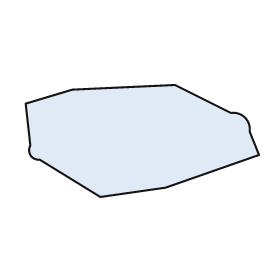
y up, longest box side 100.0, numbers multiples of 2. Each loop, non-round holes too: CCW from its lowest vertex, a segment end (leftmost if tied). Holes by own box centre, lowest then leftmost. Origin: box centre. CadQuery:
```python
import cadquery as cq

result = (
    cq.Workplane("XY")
    .moveTo(-18.0, -24.0)
    .lineTo(10.0, -20.0)
    .lineTo(50.0, -6.0)
    .lineTo(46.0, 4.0)
    .threePointArc((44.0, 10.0), (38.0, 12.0))
    .lineTo(14.0, 24.0)
    .lineTo(-30.0, 22.0)
    .lineTo(-50.0, 16.0)
    .lineTo(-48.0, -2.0)
    .threePointArc((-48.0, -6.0), (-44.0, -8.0))
    .close()
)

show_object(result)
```